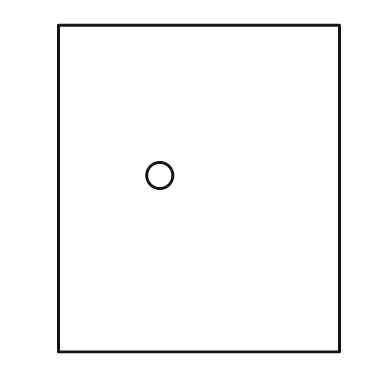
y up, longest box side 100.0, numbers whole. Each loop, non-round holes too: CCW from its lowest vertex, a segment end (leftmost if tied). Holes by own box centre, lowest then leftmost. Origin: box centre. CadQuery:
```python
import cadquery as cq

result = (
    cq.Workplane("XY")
    .moveTo(-43.0, -50.0)
    .lineTo(43.0, -50.0)
    .lineTo(43.0, 50.0)
    .lineTo(-43.0, 50.0)
    .close()
    .moveTo(-12.0, 4.0)
    .circle(4.0)
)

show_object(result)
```